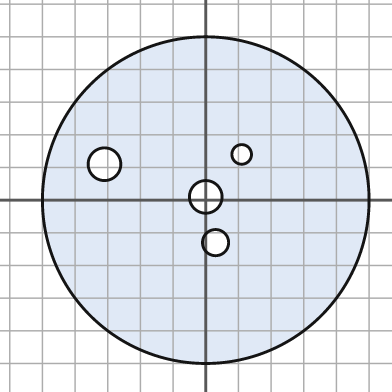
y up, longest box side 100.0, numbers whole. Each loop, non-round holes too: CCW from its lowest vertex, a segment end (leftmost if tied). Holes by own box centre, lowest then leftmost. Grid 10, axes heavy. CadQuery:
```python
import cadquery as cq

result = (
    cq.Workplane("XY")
    .moveTo(0.0, 0.0)
    .circle(50.0)
    .moveTo(3.0, -13.0)
    .circle(4.0)
    .moveTo(0.0, 1.0)
    .circle(5.0)
    .moveTo(-31.0, 11.0)
    .circle(5.0)
    .moveTo(11.0, 14.0)
    .circle(3.0)
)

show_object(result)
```